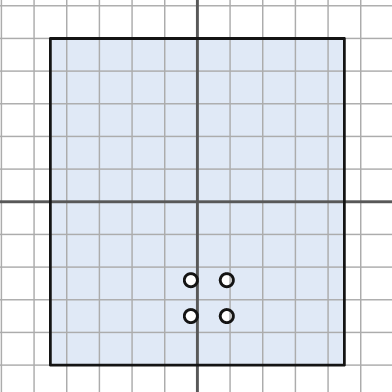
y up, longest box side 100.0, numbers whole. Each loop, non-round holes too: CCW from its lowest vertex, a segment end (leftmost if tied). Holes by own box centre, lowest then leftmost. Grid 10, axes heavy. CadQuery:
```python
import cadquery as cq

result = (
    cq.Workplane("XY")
    .moveTo(-45.0, -50.0)
    .lineTo(45.0, -50.0)
    .lineTo(45.0, 50.0)
    .lineTo(-45.0, 50.0)
    .close()
    .moveTo(-2.0, -35.0)
    .circle(2.0)
    .moveTo(9.0, -35.0)
    .circle(2.0)
    .moveTo(-2.0, -24.0)
    .circle(2.0)
    .moveTo(9.0, -24.0)
    .circle(2.0)
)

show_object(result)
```